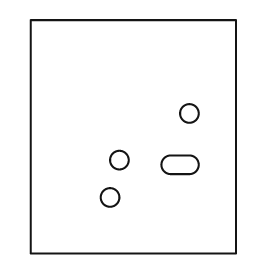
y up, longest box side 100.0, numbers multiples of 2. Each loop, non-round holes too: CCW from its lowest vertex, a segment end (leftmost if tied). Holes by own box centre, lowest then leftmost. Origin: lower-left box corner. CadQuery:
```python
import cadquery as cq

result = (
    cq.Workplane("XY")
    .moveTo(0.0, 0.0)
    .lineTo(88.0, 0.0)
    .lineTo(88.0, 100.0)
    .lineTo(0.0, 100.0)
    .close()
    .moveTo(34.0, 24.0)
    .circle(4.0)
    .moveTo(60.0, 34.0)
    .lineTo(68.0, 34.0)
    .threePointArc((72.0, 38.0), (68.0, 42.0))
    .lineTo(60.0, 42.0)
    .threePointArc((56.0, 38.0), (60.0, 34.0))
    .close()
    .moveTo(38.0, 40.0)
    .circle(4.0)
    .moveTo(68.0, 60.0)
    .circle(4.0)
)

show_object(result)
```